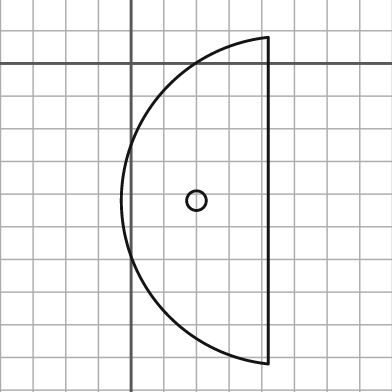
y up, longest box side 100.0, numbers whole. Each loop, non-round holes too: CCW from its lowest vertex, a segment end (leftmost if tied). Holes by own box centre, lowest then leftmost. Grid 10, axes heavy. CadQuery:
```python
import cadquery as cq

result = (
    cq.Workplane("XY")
    .moveTo(42.0, -92.0)
    .lineTo(42.0, 8.0)
    .threePointArc((-3.0, -42.0), (42.0, -92.0))
    .close()
    .moveTo(20.0, -42.0)
    .circle(3.0)
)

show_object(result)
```